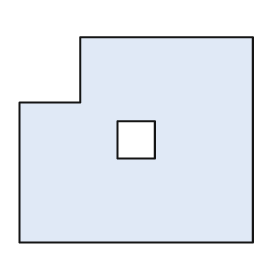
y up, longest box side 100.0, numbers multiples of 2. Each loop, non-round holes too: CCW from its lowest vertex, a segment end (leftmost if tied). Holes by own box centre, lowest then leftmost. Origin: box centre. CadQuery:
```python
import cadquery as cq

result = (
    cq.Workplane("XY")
    .moveTo(-50.0, -44.0)
    .lineTo(50.0, -44.0)
    .lineTo(50.0, 44.0)
    .lineTo(-24.0, 44.0)
    .lineTo(-24.0, 16.0)
    .lineTo(-50.0, 16.0)
    .close()
    .moveTo(-8.0, -8.0)
    .lineTo(8.0, -8.0)
    .lineTo(8.0, 8.0)
    .lineTo(-8.0, 8.0)
    .close()
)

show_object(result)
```